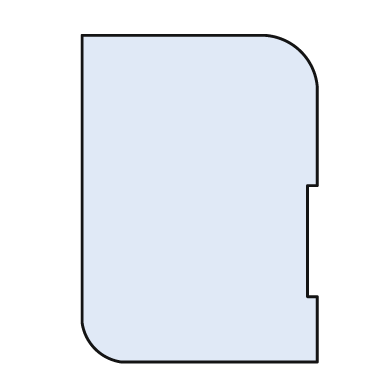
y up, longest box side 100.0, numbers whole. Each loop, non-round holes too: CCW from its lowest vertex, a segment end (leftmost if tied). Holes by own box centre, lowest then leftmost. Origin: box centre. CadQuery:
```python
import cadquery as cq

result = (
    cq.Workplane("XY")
    .moveTo(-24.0, -50.0)
    .lineTo(36.0, -50.0)
    .lineTo(36.0, -30.0)
    .lineTo(33.0, -30.0)
    .lineTo(33.0, 4.0)
    .lineTo(36.0, 4.0)
    .lineTo(36.0, 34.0)
    .threePointArc((31.0, 45.0), (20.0, 50.0))
    .lineTo(-36.0, 50.0)
    .lineTo(-36.0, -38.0)
    .threePointArc((-32.0, -46.0), (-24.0, -50.0))
    .close()
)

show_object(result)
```